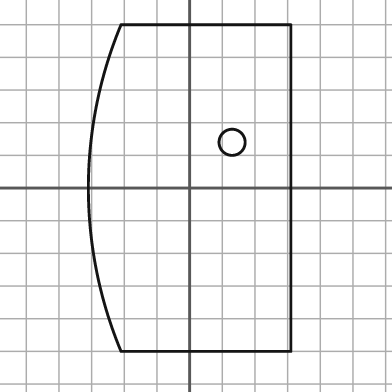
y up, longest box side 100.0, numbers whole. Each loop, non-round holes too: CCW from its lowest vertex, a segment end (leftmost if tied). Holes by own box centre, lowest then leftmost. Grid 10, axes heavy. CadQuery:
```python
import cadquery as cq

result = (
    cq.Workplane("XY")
    .moveTo(-21.0, -50.0)
    .lineTo(31.0, -50.0)
    .lineTo(31.0, 50.0)
    .lineTo(-21.0, 50.0)
    .threePointArc((-31.0, 0.0), (-21.0, -50.0))
    .close()
    .moveTo(13.0, 14.0)
    .circle(4.0)
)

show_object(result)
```